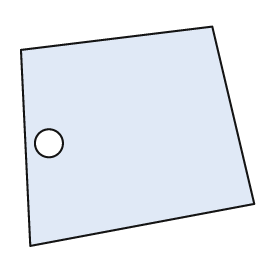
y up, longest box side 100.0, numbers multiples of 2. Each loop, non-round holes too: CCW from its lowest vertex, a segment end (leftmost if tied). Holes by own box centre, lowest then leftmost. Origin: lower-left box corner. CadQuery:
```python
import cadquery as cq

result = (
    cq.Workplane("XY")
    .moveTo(4.0, 0.0)
    .lineTo(100.0, 18.0)
    .lineTo(82.0, 94.0)
    .lineTo(0.0, 84.0)
    .close()
    .moveTo(12.0, 44.0)
    .circle(6.0)
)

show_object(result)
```